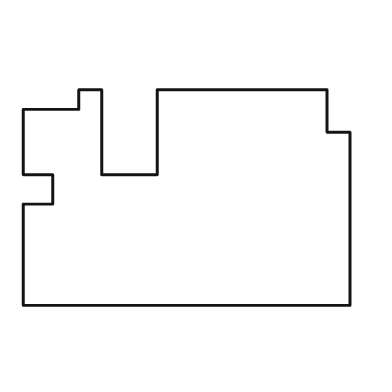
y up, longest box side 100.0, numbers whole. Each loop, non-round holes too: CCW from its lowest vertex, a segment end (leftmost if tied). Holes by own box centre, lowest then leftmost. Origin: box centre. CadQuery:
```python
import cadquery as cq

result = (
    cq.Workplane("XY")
    .moveTo(-50.0, -33.0)
    .lineTo(50.0, -33.0)
    .lineTo(50.0, 20.0)
    .lineTo(43.0, 20.0)
    .lineTo(43.0, 33.0)
    .lineTo(-9.0, 33.0)
    .lineTo(-9.0, 7.0)
    .lineTo(-26.0, 7.0)
    .lineTo(-26.0, 33.0)
    .lineTo(-33.0, 33.0)
    .lineTo(-33.0, 27.0)
    .lineTo(-50.0, 27.0)
    .lineTo(-50.0, 7.0)
    .lineTo(-41.0, 7.0)
    .lineTo(-41.0, -2.0)
    .lineTo(-50.0, -2.0)
    .close()
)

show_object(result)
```